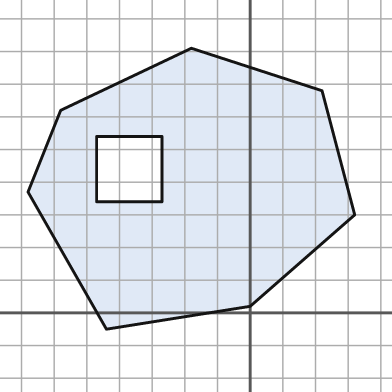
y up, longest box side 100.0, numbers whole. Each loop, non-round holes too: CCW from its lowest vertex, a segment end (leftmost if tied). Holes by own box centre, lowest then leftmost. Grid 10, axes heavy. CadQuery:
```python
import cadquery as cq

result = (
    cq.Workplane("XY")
    .moveTo(-44.0, -5.0)
    .lineTo(0.0, 2.0)
    .lineTo(32.0, 30.0)
    .lineTo(22.0, 68.0)
    .lineTo(-18.0, 81.0)
    .lineTo(-58.0, 62.0)
    .lineTo(-68.0, 37.0)
    .close()
    .moveTo(-47.0, 34.0)
    .lineTo(-27.0, 34.0)
    .lineTo(-27.0, 54.0)
    .lineTo(-47.0, 54.0)
    .close()
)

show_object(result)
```